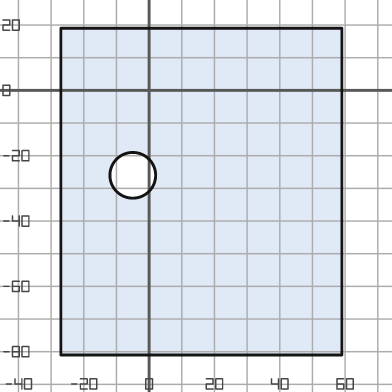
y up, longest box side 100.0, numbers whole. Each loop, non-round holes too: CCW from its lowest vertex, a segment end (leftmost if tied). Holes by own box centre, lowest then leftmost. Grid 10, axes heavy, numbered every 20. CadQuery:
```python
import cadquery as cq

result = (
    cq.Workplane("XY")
    .moveTo(-27.0, -81.0)
    .lineTo(59.0, -81.0)
    .lineTo(59.0, 19.0)
    .lineTo(-27.0, 19.0)
    .close()
    .moveTo(-5.0, -26.0)
    .circle(7.0)
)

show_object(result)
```